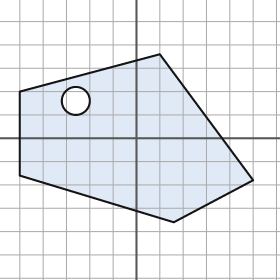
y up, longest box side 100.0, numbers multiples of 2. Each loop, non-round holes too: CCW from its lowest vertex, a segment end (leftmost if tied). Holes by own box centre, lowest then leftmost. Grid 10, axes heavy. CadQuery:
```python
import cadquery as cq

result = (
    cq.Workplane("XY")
    .moveTo(16.0, -36.0)
    .lineTo(50.0, -18.0)
    .lineTo(10.0, 36.0)
    .lineTo(-50.0, 20.0)
    .lineTo(-50.0, -16.0)
    .close()
    .moveTo(-26.0, 16.0)
    .circle(6.0)
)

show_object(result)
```